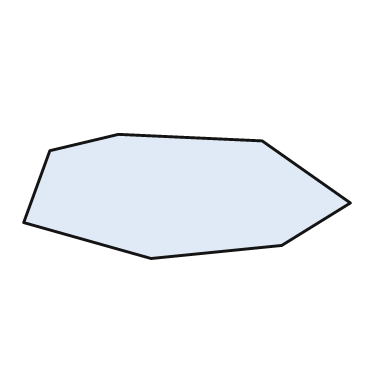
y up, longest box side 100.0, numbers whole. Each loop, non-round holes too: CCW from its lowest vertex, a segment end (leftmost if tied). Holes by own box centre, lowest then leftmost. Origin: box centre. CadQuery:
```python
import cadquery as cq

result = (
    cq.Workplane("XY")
    .moveTo(-11.0, -19.0)
    .lineTo(29.0, -15.0)
    .lineTo(50.0, -2.0)
    .lineTo(23.0, 17.0)
    .lineTo(-21.0, 19.0)
    .lineTo(-42.0, 14.0)
    .lineTo(-50.0, -8.0)
    .close()
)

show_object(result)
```